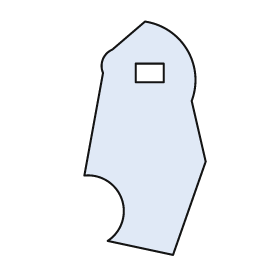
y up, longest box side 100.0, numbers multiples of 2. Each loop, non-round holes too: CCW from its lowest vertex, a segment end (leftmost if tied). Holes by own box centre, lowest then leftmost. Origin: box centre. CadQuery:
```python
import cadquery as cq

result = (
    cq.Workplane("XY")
    .moveTo(12.0, -50.0)
    .lineTo(26.0, -10.0)
    .lineTo(20.0, 16.0)
    .threePointArc((18.0, 38.0), (0.0, 50.0))
    .lineTo(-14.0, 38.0)
    .threePointArc((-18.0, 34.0), (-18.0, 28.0))
    .lineTo(-26.0, -16.0)
    .threePointArc((-10.0, -26.0), (-16.0, -44.0))
    .close()
    .moveTo(-4.0, 24.0)
    .lineTo(8.0, 24.0)
    .lineTo(8.0, 32.0)
    .lineTo(-4.0, 32.0)
    .close()
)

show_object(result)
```